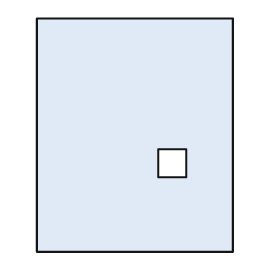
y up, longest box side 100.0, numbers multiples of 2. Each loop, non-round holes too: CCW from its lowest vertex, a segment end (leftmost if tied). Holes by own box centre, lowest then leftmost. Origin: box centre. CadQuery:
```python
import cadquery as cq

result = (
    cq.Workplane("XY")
    .moveTo(-42.0, -50.0)
    .lineTo(42.0, -50.0)
    .lineTo(42.0, 50.0)
    .lineTo(-42.0, 50.0)
    .close()
    .moveTo(10.0, -18.0)
    .lineTo(22.0, -18.0)
    .lineTo(22.0, -6.0)
    .lineTo(10.0, -6.0)
    .close()
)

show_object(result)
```